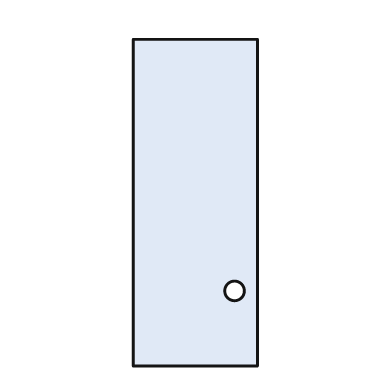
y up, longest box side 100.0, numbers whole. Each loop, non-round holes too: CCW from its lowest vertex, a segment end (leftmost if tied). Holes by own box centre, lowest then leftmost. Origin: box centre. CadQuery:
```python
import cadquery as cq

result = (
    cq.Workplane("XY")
    .moveTo(-19.0, -50.0)
    .lineTo(19.0, -50.0)
    .lineTo(19.0, 50.0)
    .lineTo(-19.0, 50.0)
    .close()
    .moveTo(12.0, -27.0)
    .circle(3.0)
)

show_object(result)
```